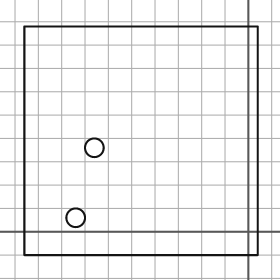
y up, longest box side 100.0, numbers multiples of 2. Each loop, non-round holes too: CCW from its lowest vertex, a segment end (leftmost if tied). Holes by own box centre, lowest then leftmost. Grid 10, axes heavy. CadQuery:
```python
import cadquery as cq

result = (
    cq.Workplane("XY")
    .moveTo(-96.0, -10.0)
    .lineTo(4.0, -10.0)
    .lineTo(4.0, 88.0)
    .lineTo(-96.0, 88.0)
    .close()
    .moveTo(-74.0, 6.0)
    .circle(4.0)
    .moveTo(-66.0, 36.0)
    .circle(4.0)
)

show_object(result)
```